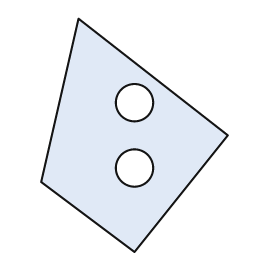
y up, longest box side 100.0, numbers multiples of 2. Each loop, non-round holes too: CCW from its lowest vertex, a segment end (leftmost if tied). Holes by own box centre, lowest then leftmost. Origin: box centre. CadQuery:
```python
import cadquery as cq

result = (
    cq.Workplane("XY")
    .moveTo(0.0, -50.0)
    .lineTo(40.0, 0.0)
    .lineTo(-24.0, 50.0)
    .lineTo(-40.0, -20.0)
    .close()
    .moveTo(0.0, -14.0)
    .circle(8.0)
    .moveTo(0.0, 14.0)
    .circle(8.0)
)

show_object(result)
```